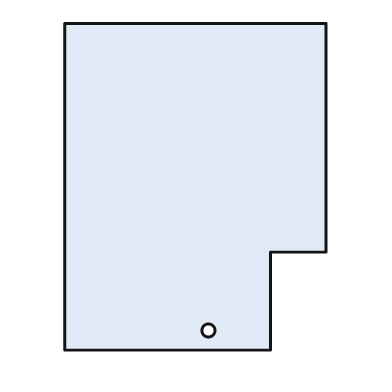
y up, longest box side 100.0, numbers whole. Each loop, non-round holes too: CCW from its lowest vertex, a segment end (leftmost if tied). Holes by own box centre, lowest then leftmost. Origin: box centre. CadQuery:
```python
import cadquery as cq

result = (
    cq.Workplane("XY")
    .moveTo(-40.0, -50.0)
    .lineTo(23.0, -50.0)
    .lineTo(23.0, -20.0)
    .lineTo(40.0, -20.0)
    .lineTo(40.0, 50.0)
    .lineTo(-40.0, 50.0)
    .close()
    .moveTo(4.0, -44.0)
    .circle(2.0)
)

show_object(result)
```